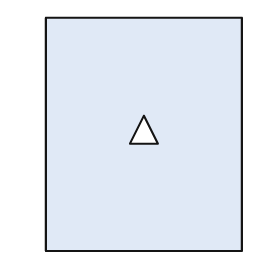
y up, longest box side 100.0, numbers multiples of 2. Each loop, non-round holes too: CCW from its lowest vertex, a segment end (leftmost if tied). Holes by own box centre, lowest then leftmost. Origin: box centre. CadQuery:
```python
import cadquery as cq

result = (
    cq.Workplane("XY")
    .moveTo(-42.0, -50.0)
    .lineTo(42.0, -50.0)
    .lineTo(42.0, 50.0)
    .lineTo(-42.0, 50.0)
    .close()
    .moveTo(-6.0, -4.0)
    .lineTo(6.0, -4.0)
    .lineTo(0.0, 8.0)
    .close()
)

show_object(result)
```